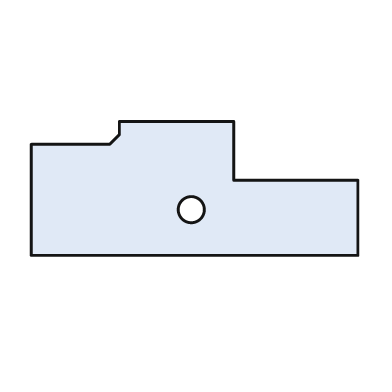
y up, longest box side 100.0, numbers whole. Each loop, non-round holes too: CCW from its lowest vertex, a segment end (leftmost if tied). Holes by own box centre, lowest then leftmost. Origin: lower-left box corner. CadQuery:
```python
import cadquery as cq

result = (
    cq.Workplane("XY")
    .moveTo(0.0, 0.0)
    .lineTo(100.0, 0.0)
    .lineTo(100.0, 23.0)
    .lineTo(62.0, 23.0)
    .lineTo(62.0, 41.0)
    .lineTo(27.0, 41.0)
    .lineTo(27.0, 37.0)
    .lineTo(24.0, 34.0)
    .lineTo(0.0, 34.0)
    .close()
    .moveTo(49.0, 14.0)
    .circle(4.0)
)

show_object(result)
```